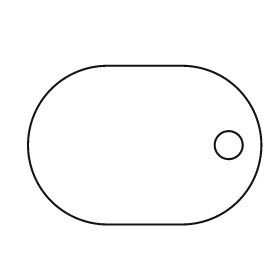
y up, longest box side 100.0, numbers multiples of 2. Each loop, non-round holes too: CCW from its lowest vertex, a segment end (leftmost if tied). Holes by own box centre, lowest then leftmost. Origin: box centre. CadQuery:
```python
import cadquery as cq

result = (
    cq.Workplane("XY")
    .moveTo(-16.0, -34.0)
    .lineTo(16.0, -34.0)
    .threePointArc((50.0, 0.0), (16.0, 34.0))
    .lineTo(-16.0, 34.0)
    .threePointArc((-50.0, 0.0), (-16.0, -34.0))
    .close()
    .moveTo(36.0, 0.0)
    .circle(6.0)
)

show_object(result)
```